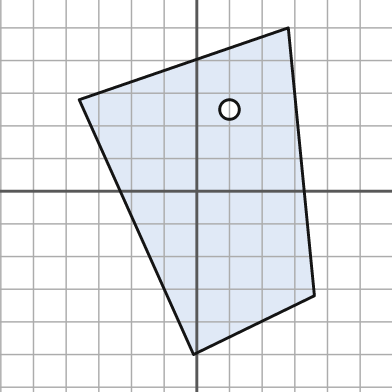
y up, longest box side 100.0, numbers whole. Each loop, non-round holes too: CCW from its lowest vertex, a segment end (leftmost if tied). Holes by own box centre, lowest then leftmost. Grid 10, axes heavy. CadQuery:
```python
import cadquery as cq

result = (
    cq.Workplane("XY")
    .moveTo(-1.0, -50.0)
    .lineTo(36.0, -32.0)
    .lineTo(28.0, 50.0)
    .lineTo(-36.0, 28.0)
    .close()
    .moveTo(10.0, 25.0)
    .circle(3.0)
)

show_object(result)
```